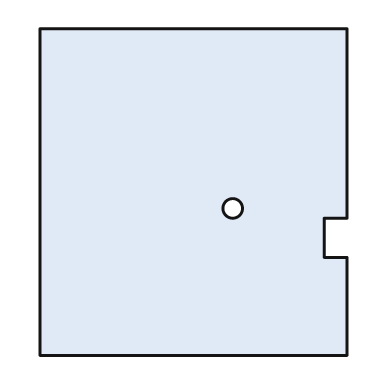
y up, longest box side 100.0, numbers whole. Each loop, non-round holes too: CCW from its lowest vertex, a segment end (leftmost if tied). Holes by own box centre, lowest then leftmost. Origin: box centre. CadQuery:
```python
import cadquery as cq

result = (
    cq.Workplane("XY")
    .moveTo(-47.0, -50.0)
    .lineTo(47.0, -50.0)
    .lineTo(47.0, -20.0)
    .lineTo(40.0, -20.0)
    .lineTo(40.0, -8.0)
    .lineTo(47.0, -8.0)
    .lineTo(47.0, 50.0)
    .lineTo(-47.0, 50.0)
    .close()
    .moveTo(12.0, -5.0)
    .circle(3.0)
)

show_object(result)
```